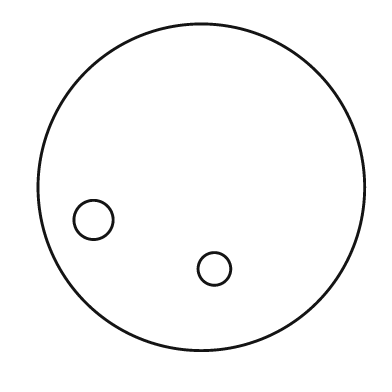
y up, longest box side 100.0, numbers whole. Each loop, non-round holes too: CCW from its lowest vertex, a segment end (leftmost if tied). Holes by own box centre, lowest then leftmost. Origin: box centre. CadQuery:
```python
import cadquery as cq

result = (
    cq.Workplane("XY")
    .moveTo(0.0, 0.0)
    .circle(50.0)
    .moveTo(4.0, -25.0)
    .circle(5.0)
    .moveTo(-33.0, -10.0)
    .circle(6.0)
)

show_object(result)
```